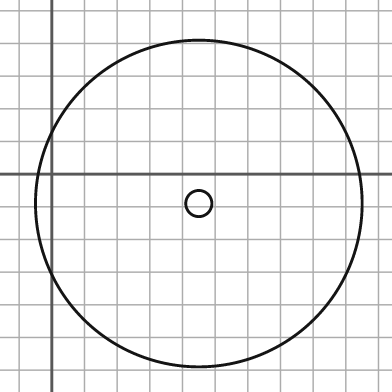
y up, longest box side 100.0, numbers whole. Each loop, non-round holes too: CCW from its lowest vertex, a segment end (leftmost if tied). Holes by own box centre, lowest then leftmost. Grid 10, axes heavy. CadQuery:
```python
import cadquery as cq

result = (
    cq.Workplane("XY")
    .moveTo(45.0, -9.0)
    .circle(50.0)
    .moveTo(45.0, -9.0)
    .circle(4.0)
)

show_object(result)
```